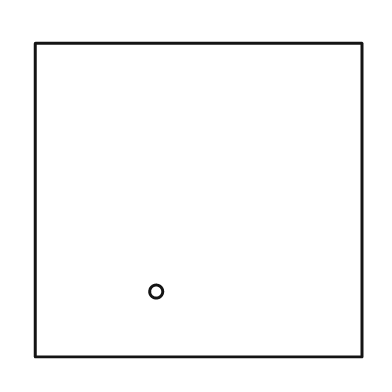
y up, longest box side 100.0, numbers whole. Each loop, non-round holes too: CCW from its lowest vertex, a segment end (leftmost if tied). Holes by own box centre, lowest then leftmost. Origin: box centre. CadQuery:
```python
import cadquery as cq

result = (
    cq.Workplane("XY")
    .moveTo(-50.0, -48.0)
    .lineTo(50.0, -48.0)
    .lineTo(50.0, 48.0)
    .lineTo(-50.0, 48.0)
    .close()
    .moveTo(-13.0, -28.0)
    .circle(2.0)
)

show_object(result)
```